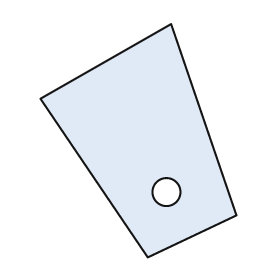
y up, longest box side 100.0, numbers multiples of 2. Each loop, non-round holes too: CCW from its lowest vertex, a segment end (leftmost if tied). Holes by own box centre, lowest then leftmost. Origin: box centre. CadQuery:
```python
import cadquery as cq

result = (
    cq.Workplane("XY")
    .moveTo(4.0, -50.0)
    .lineTo(42.0, -32.0)
    .lineTo(14.0, 50.0)
    .lineTo(-42.0, 18.0)
    .close()
    .moveTo(12.0, -22.0)
    .circle(6.0)
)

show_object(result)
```